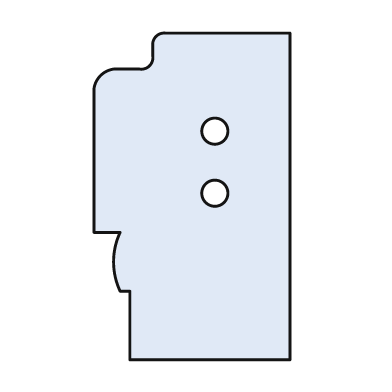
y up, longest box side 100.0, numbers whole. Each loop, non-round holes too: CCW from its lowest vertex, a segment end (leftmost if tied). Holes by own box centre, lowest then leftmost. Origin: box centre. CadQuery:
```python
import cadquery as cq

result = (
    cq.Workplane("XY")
    .moveTo(-19.0, -50.0)
    .lineTo(30.0, -50.0)
    .lineTo(30.0, 50.0)
    .lineTo(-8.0, 50.0)
    .threePointArc((-11.0, 49.0), (-12.0, 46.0))
    .lineTo(-12.0, 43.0)
    .threePointArc((-13.0, 40.0), (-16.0, 39.0))
    .lineTo(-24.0, 39.0)
    .threePointArc((-28.0, 37.0), (-30.0, 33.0))
    .lineTo(-30.0, -11.0)
    .lineTo(-22.0, -11.0)
    .threePointArc((-24.0, -20.0), (-22.0, -29.0))
    .lineTo(-19.0, -29.0)
    .close()
    .moveTo(7.0, 1.0)
    .circle(4.0)
    .moveTo(7.0, 20.0)
    .circle(4.0)
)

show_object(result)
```